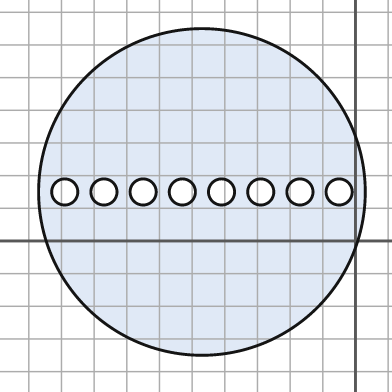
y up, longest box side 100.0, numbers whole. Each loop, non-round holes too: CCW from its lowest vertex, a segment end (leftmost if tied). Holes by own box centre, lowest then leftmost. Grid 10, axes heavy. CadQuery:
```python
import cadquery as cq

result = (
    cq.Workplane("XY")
    .moveTo(-47.0, 15.0)
    .circle(50.0)
    .moveTo(-89.0, 15.0)
    .circle(4.0)
    .moveTo(-77.0, 15.0)
    .circle(4.0)
    .moveTo(-65.0, 15.0)
    .circle(4.0)
    .moveTo(-53.0, 15.0)
    .circle(4.0)
    .moveTo(-41.0, 15.0)
    .circle(4.0)
    .moveTo(-29.0, 15.0)
    .circle(4.0)
    .moveTo(-17.0, 15.0)
    .circle(4.0)
    .moveTo(-5.0, 15.0)
    .circle(4.0)
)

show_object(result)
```